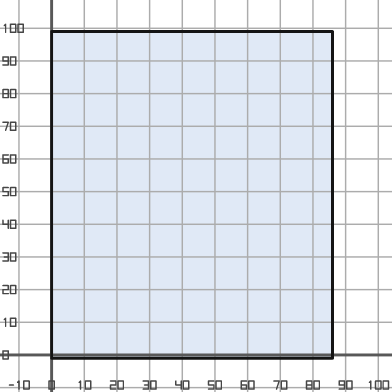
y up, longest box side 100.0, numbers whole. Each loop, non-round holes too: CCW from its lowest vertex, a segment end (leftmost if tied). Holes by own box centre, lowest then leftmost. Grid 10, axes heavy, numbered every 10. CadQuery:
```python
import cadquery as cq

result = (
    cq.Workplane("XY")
    .moveTo(0.0, -1.0)
    .lineTo(86.0, -1.0)
    .lineTo(86.0, 99.0)
    .lineTo(0.0, 99.0)
    .close()
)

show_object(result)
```